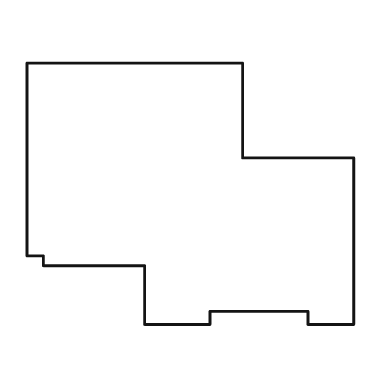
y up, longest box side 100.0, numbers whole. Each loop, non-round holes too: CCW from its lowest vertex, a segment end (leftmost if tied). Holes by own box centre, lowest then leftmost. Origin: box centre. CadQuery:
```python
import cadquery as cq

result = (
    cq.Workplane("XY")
    .moveTo(-14.0, -40.0)
    .lineTo(6.0, -40.0)
    .lineTo(6.0, -36.0)
    .lineTo(36.0, -36.0)
    .lineTo(36.0, -40.0)
    .lineTo(50.0, -40.0)
    .lineTo(50.0, 11.0)
    .lineTo(16.0, 11.0)
    .lineTo(16.0, 40.0)
    .lineTo(-50.0, 40.0)
    .lineTo(-50.0, -19.0)
    .lineTo(-45.0, -19.0)
    .lineTo(-45.0, -22.0)
    .lineTo(-14.0, -22.0)
    .close()
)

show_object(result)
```